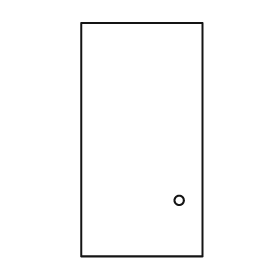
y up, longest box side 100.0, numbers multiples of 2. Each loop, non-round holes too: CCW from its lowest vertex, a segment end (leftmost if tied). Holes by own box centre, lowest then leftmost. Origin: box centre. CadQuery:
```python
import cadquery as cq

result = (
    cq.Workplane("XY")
    .moveTo(-26.0, -50.0)
    .lineTo(26.0, -50.0)
    .lineTo(26.0, 50.0)
    .lineTo(-26.0, 50.0)
    .close()
    .moveTo(16.0, -26.0)
    .circle(2.0)
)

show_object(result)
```